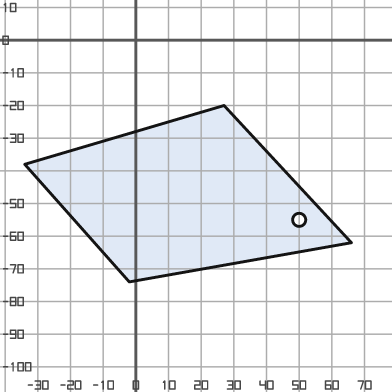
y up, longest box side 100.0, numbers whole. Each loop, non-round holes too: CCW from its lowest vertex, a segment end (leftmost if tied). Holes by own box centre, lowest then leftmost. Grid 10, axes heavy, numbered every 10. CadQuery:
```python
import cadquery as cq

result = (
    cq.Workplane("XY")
    .moveTo(-2.0, -74.0)
    .lineTo(66.0, -62.0)
    .lineTo(27.0, -20.0)
    .lineTo(-34.0, -38.0)
    .close()
    .moveTo(50.0, -55.0)
    .circle(2.0)
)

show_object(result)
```